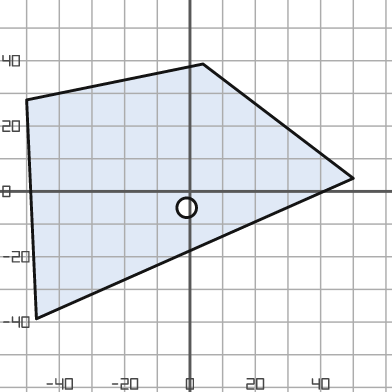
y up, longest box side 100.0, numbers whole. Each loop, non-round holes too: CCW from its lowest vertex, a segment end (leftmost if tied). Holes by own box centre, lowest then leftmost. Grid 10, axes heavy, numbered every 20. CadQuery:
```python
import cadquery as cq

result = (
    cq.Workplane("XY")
    .moveTo(-47.0, -39.0)
    .lineTo(50.0, 4.0)
    .lineTo(4.0, 39.0)
    .lineTo(-50.0, 28.0)
    .close()
    .moveTo(-1.0, -5.0)
    .circle(3.0)
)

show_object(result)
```